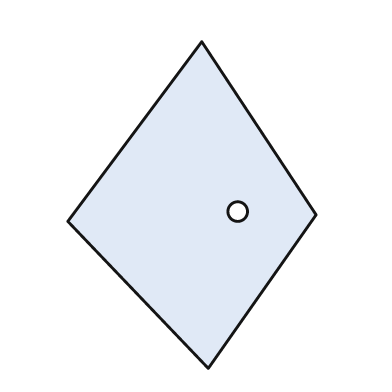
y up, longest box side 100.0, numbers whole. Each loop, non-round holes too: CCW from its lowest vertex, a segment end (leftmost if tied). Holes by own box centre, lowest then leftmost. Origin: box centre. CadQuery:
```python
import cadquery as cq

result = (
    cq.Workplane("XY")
    .moveTo(5.0, -50.0)
    .lineTo(38.0, -3.0)
    .lineTo(3.0, 50.0)
    .lineTo(-38.0, -5.0)
    .close()
    .moveTo(14.0, -2.0)
    .circle(3.0)
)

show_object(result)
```